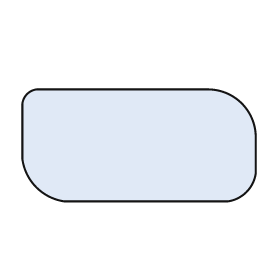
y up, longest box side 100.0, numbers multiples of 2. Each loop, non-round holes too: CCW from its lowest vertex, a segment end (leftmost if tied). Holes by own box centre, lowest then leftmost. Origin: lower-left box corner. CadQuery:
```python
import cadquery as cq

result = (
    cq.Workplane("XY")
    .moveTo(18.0, 0.0)
    .lineTo(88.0, 0.0)
    .threePointArc((96.0, 4.0), (100.0, 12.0))
    .lineTo(100.0, 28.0)
    .threePointArc((94.0, 42.0), (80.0, 48.0))
    .lineTo(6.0, 48.0)
    .threePointArc((2.0, 46.0), (0.0, 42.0))
    .lineTo(0.0, 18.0)
    .threePointArc((6.0, 6.0), (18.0, 0.0))
    .close()
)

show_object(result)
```